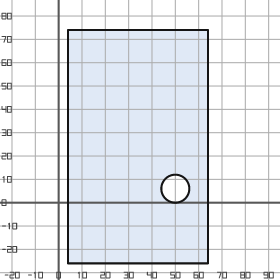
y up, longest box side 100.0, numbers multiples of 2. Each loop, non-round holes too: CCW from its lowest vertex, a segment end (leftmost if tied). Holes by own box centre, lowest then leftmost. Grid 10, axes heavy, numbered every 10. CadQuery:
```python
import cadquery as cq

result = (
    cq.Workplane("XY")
    .moveTo(4.0, -26.0)
    .lineTo(64.0, -26.0)
    .lineTo(64.0, 74.0)
    .lineTo(4.0, 74.0)
    .close()
    .moveTo(50.0, 6.0)
    .circle(6.0)
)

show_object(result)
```